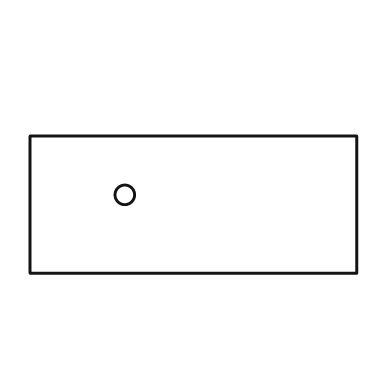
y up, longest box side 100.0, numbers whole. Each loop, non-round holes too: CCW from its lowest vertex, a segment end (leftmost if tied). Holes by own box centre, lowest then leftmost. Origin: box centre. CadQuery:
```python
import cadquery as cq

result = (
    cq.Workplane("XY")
    .moveTo(-50.0, -21.0)
    .lineTo(50.0, -21.0)
    .lineTo(50.0, 21.0)
    .lineTo(-50.0, 21.0)
    .close()
    .moveTo(-21.0, 3.0)
    .circle(3.0)
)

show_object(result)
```